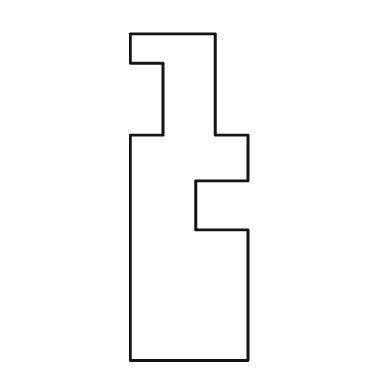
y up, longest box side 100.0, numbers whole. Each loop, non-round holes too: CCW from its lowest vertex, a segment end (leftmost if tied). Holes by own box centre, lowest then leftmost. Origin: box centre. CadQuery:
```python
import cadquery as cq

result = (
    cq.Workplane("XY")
    .moveTo(-18.0, -50.0)
    .lineTo(18.0, -50.0)
    .lineTo(18.0, -10.0)
    .lineTo(2.0, -10.0)
    .lineTo(2.0, 5.0)
    .lineTo(18.0, 5.0)
    .lineTo(18.0, 19.0)
    .lineTo(8.0, 19.0)
    .lineTo(8.0, 50.0)
    .lineTo(-18.0, 50.0)
    .lineTo(-18.0, 41.0)
    .lineTo(-8.0, 41.0)
    .lineTo(-8.0, 19.0)
    .lineTo(-18.0, 19.0)
    .close()
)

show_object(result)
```